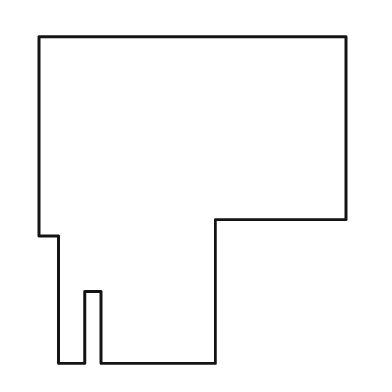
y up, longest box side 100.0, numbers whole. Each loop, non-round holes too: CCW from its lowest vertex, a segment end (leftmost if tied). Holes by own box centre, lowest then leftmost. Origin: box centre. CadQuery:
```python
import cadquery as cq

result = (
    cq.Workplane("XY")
    .moveTo(-41.0, -50.0)
    .lineTo(-33.0, -50.0)
    .lineTo(-33.0, -28.0)
    .lineTo(-28.0, -28.0)
    .lineTo(-28.0, -50.0)
    .lineTo(7.0, -50.0)
    .lineTo(7.0, -6.0)
    .lineTo(47.0, -6.0)
    .lineTo(47.0, 50.0)
    .lineTo(-47.0, 50.0)
    .lineTo(-47.0, -11.0)
    .lineTo(-41.0, -11.0)
    .close()
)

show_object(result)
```